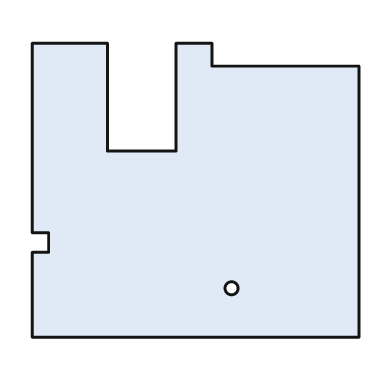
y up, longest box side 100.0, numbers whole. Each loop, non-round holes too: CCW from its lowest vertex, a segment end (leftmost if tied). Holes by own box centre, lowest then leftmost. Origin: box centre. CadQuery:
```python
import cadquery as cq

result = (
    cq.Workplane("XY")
    .moveTo(-50.0, -45.0)
    .lineTo(50.0, -45.0)
    .lineTo(50.0, 38.0)
    .lineTo(5.0, 38.0)
    .lineTo(5.0, 45.0)
    .lineTo(-6.0, 45.0)
    .lineTo(-6.0, 12.0)
    .lineTo(-27.0, 12.0)
    .lineTo(-27.0, 45.0)
    .lineTo(-50.0, 45.0)
    .lineTo(-50.0, -13.0)
    .lineTo(-45.0, -13.0)
    .lineTo(-45.0, -19.0)
    .lineTo(-50.0, -19.0)
    .close()
    .moveTo(11.0, -30.0)
    .circle(2.0)
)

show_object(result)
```